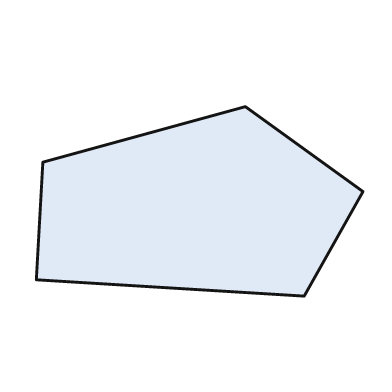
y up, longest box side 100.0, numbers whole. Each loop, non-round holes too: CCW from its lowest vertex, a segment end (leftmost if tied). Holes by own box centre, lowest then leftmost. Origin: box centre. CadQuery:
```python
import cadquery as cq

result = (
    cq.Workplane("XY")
    .moveTo(32.0, -29.0)
    .lineTo(50.0, 3.0)
    .lineTo(14.0, 29.0)
    .lineTo(-48.0, 12.0)
    .lineTo(-50.0, -24.0)
    .close()
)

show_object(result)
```